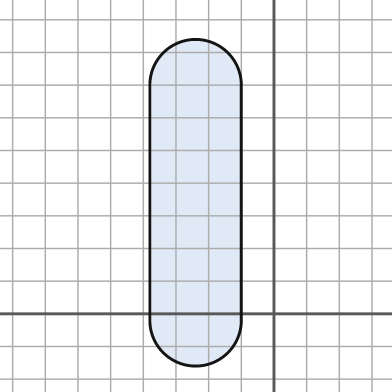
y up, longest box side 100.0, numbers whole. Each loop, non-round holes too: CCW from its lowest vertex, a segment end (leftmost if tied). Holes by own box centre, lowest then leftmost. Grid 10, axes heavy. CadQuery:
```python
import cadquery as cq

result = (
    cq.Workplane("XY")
    .moveTo(-38.0, -2.0)
    .threePointArc((-24.0, -16.0), (-10.0, -2.0))
    .lineTo(-10.0, 70.0)
    .threePointArc((-24.0, 84.0), (-38.0, 70.0))
    .close()
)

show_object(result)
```